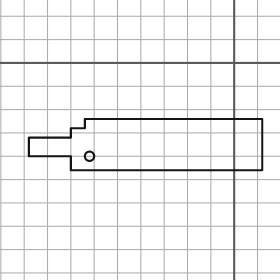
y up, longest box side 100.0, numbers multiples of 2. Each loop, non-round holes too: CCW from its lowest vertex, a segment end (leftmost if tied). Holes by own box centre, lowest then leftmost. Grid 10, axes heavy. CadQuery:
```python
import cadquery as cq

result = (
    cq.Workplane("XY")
    .moveTo(-70.0, -46.0)
    .lineTo(12.0, -46.0)
    .lineTo(12.0, -24.0)
    .lineTo(-64.0, -24.0)
    .lineTo(-64.0, -28.0)
    .lineTo(-70.0, -28.0)
    .lineTo(-70.0, -32.0)
    .lineTo(-88.0, -32.0)
    .lineTo(-88.0, -40.0)
    .lineTo(-70.0, -40.0)
    .close()
    .moveTo(-62.0, -40.0)
    .circle(2.0)
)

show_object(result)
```